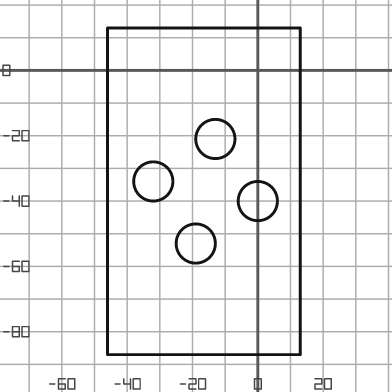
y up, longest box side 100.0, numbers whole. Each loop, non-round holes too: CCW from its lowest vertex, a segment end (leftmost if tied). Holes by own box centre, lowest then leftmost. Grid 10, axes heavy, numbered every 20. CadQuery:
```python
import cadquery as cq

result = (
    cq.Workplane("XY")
    .moveTo(-46.0, -87.0)
    .lineTo(13.0, -87.0)
    .lineTo(13.0, 13.0)
    .lineTo(-46.0, 13.0)
    .close()
    .moveTo(-19.0, -53.0)
    .circle(6.0)
    .moveTo(0.0, -40.0)
    .circle(6.0)
    .moveTo(-32.0, -34.0)
    .circle(6.0)
    .moveTo(-13.0, -21.0)
    .circle(6.0)
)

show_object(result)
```